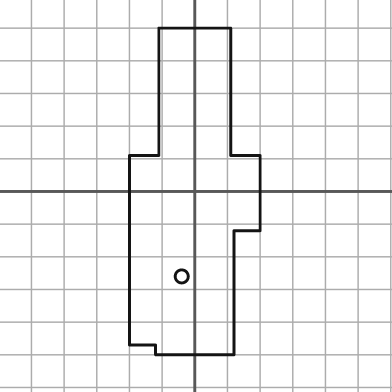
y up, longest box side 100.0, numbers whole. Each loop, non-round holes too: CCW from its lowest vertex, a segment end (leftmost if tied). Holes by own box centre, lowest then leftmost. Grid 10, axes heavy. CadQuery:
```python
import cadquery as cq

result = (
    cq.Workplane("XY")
    .moveTo(-12.0, -50.0)
    .lineTo(12.0, -50.0)
    .lineTo(12.0, -12.0)
    .lineTo(20.0, -12.0)
    .lineTo(20.0, 11.0)
    .lineTo(11.0, 11.0)
    .lineTo(11.0, 50.0)
    .lineTo(-11.0, 50.0)
    .lineTo(-11.0, 11.0)
    .lineTo(-20.0, 11.0)
    .lineTo(-20.0, -47.0)
    .lineTo(-12.0, -47.0)
    .close()
    .moveTo(-4.0, -26.0)
    .circle(2.0)
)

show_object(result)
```